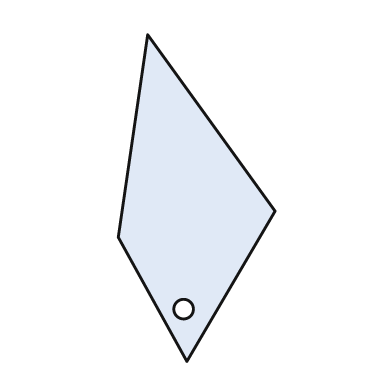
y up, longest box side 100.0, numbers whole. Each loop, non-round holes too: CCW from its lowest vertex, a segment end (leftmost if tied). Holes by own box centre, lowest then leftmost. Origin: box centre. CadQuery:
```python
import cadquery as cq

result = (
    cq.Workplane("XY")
    .moveTo(-3.0, -50.0)
    .lineTo(24.0, -4.0)
    .lineTo(-15.0, 50.0)
    .lineTo(-24.0, -12.0)
    .close()
    .moveTo(-4.0, -34.0)
    .circle(3.0)
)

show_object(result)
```